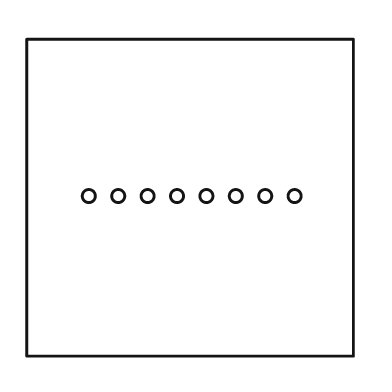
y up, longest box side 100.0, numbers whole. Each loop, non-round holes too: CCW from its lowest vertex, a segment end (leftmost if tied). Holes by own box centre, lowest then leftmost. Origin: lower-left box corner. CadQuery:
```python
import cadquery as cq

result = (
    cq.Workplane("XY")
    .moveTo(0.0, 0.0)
    .lineTo(100.0, 0.0)
    .lineTo(100.0, 97.0)
    .lineTo(0.0, 97.0)
    .close()
    .moveTo(19.0, 49.0)
    .circle(2.0)
    .moveTo(28.0, 49.0)
    .circle(2.0)
    .moveTo(37.0, 49.0)
    .circle(2.0)
    .moveTo(46.0, 49.0)
    .circle(2.0)
    .moveTo(55.0, 49.0)
    .circle(2.0)
    .moveTo(64.0, 49.0)
    .circle(2.0)
    .moveTo(73.0, 49.0)
    .circle(2.0)
    .moveTo(82.0, 49.0)
    .circle(2.0)
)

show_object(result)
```